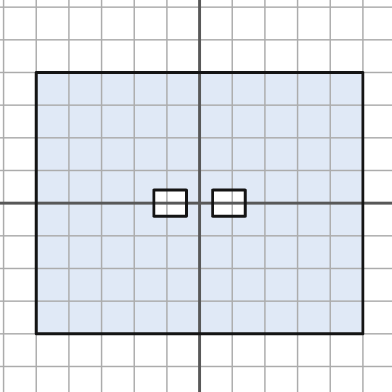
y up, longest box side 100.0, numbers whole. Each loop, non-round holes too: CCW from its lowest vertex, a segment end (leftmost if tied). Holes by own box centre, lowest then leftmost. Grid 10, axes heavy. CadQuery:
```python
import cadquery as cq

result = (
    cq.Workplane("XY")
    .moveTo(-50.0, -40.0)
    .lineTo(50.0, -40.0)
    .lineTo(50.0, 40.0)
    .lineTo(-50.0, 40.0)
    .close()
    .moveTo(-14.0, -4.0)
    .lineTo(-4.0, -4.0)
    .lineTo(-4.0, 4.0)
    .lineTo(-14.0, 4.0)
    .close()
    .moveTo(4.0, -4.0)
    .lineTo(14.0, -4.0)
    .lineTo(14.0, 4.0)
    .lineTo(4.0, 4.0)
    .close()
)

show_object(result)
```